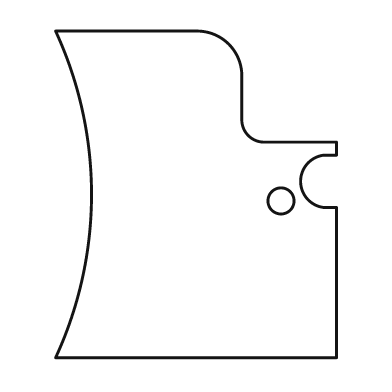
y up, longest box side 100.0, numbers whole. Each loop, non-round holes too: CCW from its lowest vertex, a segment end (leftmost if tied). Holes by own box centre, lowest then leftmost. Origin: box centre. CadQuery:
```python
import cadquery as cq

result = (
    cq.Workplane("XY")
    .moveTo(-43.0, -50.0)
    .lineTo(43.0, -50.0)
    .lineTo(43.0, -4.0)
    .lineTo(39.0, -4.0)
    .threePointArc((32.0, 4.0), (39.0, 12.0))
    .lineTo(43.0, 12.0)
    .lineTo(43.0, 16.0)
    .lineTo(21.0, 16.0)
    .threePointArc((16.0, 18.0), (14.0, 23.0))
    .lineTo(14.0, 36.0)
    .threePointArc((10.0, 46.0), (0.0, 50.0))
    .lineTo(-43.0, 50.0)
    .threePointArc((-32.0, 0.0), (-43.0, -50.0))
    .close()
    .moveTo(26.0, -2.0)
    .circle(4.0)
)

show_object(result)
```